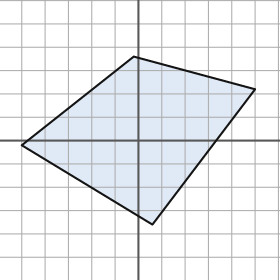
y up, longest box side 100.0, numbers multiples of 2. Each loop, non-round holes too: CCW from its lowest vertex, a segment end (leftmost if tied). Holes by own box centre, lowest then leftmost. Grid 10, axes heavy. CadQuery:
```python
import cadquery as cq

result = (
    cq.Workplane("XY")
    .moveTo(6.0, -36.0)
    .lineTo(50.0, 22.0)
    .lineTo(-2.0, 36.0)
    .lineTo(-50.0, -2.0)
    .close()
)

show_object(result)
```